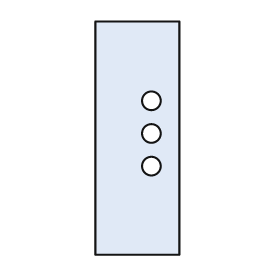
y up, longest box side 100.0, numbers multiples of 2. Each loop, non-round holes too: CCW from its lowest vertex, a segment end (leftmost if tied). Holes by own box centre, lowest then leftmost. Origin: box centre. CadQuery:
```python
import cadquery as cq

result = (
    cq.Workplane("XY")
    .moveTo(-18.0, -50.0)
    .lineTo(18.0, -50.0)
    .lineTo(18.0, 50.0)
    .lineTo(-18.0, 50.0)
    .close()
    .moveTo(6.0, -12.0)
    .circle(4.0)
    .moveTo(6.0, 2.0)
    .circle(4.0)
    .moveTo(6.0, 16.0)
    .circle(4.0)
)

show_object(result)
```